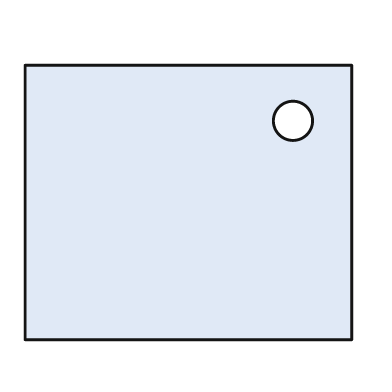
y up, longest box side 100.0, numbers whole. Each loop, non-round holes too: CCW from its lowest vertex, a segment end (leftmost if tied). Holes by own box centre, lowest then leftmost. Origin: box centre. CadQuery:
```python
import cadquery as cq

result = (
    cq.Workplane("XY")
    .moveTo(-50.0, -42.0)
    .lineTo(50.0, -42.0)
    .lineTo(50.0, 42.0)
    .lineTo(-50.0, 42.0)
    .close()
    .moveTo(32.0, 25.0)
    .circle(6.0)
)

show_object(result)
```